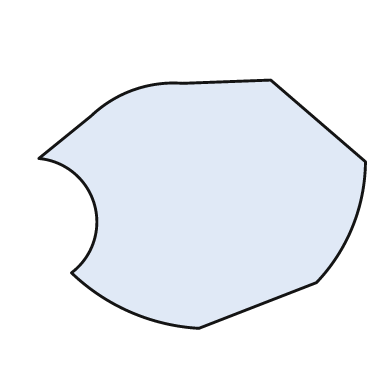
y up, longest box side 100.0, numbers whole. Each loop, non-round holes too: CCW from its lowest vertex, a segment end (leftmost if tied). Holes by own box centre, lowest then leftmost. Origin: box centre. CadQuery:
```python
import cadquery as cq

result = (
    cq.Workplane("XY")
    .moveTo(-1.0, -38.0)
    .lineTo(35.0, -24.0)
    .threePointArc((46.0, -7.0), (50.0, 13.0))
    .lineTo(21.0, 38.0)
    .lineTo(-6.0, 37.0)
    .threePointArc((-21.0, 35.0), (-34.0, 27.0))
    .lineTo(-50.0, 14.0)
    .threePointArc((-33.0, 0.0), (-40.0, -21.0))
    .threePointArc((-22.0, -33.0), (-1.0, -38.0))
    .close()
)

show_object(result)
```